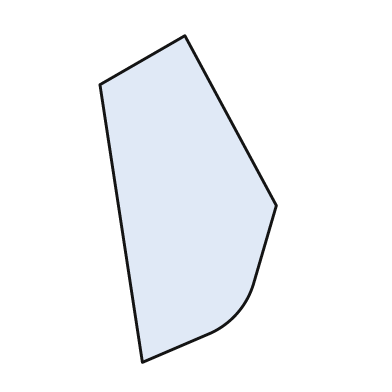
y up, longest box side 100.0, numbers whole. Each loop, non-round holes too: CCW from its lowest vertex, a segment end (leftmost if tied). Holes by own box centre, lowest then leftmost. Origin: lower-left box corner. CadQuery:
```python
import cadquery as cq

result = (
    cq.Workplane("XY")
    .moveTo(13.0, 0.0)
    .lineTo(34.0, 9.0)
    .threePointArc((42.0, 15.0), (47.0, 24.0))
    .lineTo(54.0, 48.0)
    .lineTo(26.0, 100.0)
    .lineTo(0.0, 85.0)
    .close()
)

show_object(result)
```